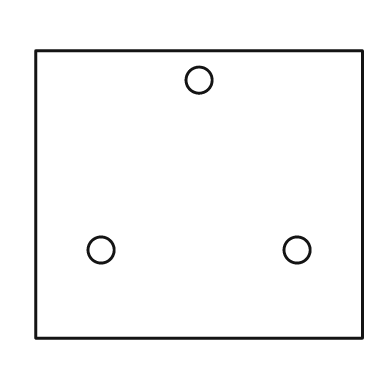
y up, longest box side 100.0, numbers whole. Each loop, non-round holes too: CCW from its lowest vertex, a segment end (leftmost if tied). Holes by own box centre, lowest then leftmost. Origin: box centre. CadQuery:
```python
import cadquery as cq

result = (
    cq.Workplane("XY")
    .moveTo(-50.0, -44.0)
    .lineTo(50.0, -44.0)
    .lineTo(50.0, 44.0)
    .lineTo(-50.0, 44.0)
    .close()
    .moveTo(-30.0, -17.0)
    .circle(4.0)
    .moveTo(30.0, -17.0)
    .circle(4.0)
    .moveTo(0.0, 35.0)
    .circle(4.0)
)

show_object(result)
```